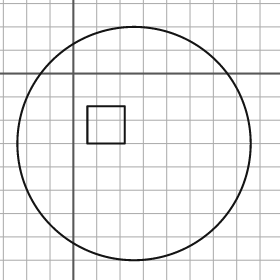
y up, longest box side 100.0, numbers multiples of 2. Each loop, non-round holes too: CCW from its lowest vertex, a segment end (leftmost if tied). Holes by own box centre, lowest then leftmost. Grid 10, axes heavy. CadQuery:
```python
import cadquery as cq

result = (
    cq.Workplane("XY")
    .moveTo(26.0, -30.0)
    .circle(50.0)
    .moveTo(6.0, -30.0)
    .lineTo(22.0, -30.0)
    .lineTo(22.0, -14.0)
    .lineTo(6.0, -14.0)
    .close()
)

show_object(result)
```